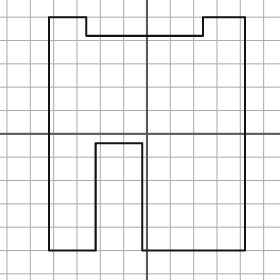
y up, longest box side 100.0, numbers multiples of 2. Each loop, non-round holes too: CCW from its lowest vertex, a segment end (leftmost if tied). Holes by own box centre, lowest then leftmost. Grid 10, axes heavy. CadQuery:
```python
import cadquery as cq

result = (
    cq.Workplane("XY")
    .moveTo(-42.0, -50.0)
    .lineTo(-22.0, -50.0)
    .lineTo(-22.0, -4.0)
    .lineTo(-2.0, -4.0)
    .lineTo(-2.0, -50.0)
    .lineTo(42.0, -50.0)
    .lineTo(42.0, 50.0)
    .lineTo(24.0, 50.0)
    .lineTo(24.0, 42.0)
    .lineTo(-26.0, 42.0)
    .lineTo(-26.0, 50.0)
    .lineTo(-42.0, 50.0)
    .close()
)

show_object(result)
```